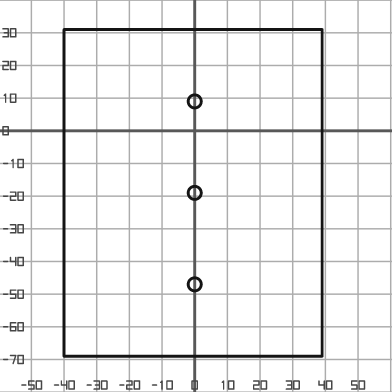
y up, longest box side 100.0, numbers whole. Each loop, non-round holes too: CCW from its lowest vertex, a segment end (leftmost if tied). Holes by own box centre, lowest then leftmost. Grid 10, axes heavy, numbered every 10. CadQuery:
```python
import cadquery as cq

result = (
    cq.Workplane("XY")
    .moveTo(-40.0, -69.0)
    .lineTo(39.0, -69.0)
    .lineTo(39.0, 31.0)
    .lineTo(-40.0, 31.0)
    .close()
    .moveTo(0.0, -47.0)
    .circle(2.0)
    .moveTo(0.0, -19.0)
    .circle(2.0)
    .moveTo(0.0, 9.0)
    .circle(2.0)
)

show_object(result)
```